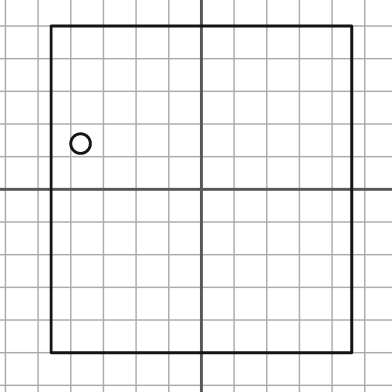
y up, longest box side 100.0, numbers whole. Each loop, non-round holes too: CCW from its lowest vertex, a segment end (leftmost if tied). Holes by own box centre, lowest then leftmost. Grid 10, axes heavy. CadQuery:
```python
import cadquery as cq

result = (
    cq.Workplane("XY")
    .moveTo(-46.0, -50.0)
    .lineTo(46.0, -50.0)
    .lineTo(46.0, 50.0)
    .lineTo(-46.0, 50.0)
    .close()
    .moveTo(-37.0, 14.0)
    .circle(3.0)
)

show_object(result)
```